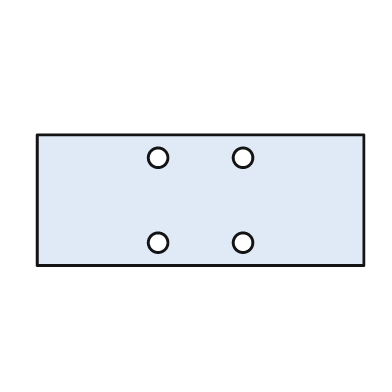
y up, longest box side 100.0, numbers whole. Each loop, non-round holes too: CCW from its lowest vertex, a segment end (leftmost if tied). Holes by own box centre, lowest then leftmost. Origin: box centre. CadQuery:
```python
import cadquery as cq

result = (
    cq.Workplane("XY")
    .moveTo(-50.0, -20.0)
    .lineTo(50.0, -20.0)
    .lineTo(50.0, 20.0)
    .lineTo(-50.0, 20.0)
    .close()
    .moveTo(-13.0, -13.0)
    .circle(3.0)
    .moveTo(13.0, -13.0)
    .circle(3.0)
    .moveTo(-13.0, 13.0)
    .circle(3.0)
    .moveTo(13.0, 13.0)
    .circle(3.0)
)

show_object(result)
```